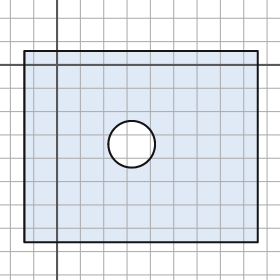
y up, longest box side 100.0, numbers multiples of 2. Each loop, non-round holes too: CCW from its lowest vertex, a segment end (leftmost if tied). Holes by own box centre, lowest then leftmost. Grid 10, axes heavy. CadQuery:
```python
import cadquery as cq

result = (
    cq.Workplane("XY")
    .moveTo(-14.0, -76.0)
    .lineTo(86.0, -76.0)
    .lineTo(86.0, 6.0)
    .lineTo(-14.0, 6.0)
    .close()
    .moveTo(32.0, -34.0)
    .circle(10.0)
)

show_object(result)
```